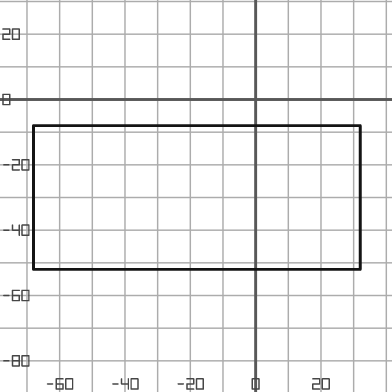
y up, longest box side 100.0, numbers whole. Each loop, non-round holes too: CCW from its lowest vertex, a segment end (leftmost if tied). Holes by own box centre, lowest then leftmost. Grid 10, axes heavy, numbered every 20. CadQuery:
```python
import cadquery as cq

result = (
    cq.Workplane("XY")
    .moveTo(-68.0, -52.0)
    .lineTo(32.0, -52.0)
    .lineTo(32.0, -8.0)
    .lineTo(-68.0, -8.0)
    .close()
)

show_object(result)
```